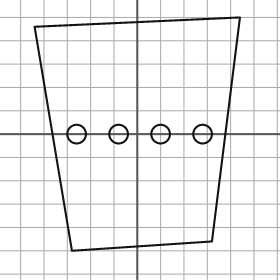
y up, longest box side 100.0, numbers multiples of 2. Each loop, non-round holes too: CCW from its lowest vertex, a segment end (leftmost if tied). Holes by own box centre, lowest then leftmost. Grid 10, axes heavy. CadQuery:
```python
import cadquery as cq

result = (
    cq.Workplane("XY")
    .moveTo(-28.0, -50.0)
    .lineTo(32.0, -46.0)
    .lineTo(44.0, 50.0)
    .lineTo(-44.0, 46.0)
    .close()
    .moveTo(-26.0, 0.0)
    .circle(4.0)
    .moveTo(-8.0, 0.0)
    .circle(4.0)
    .moveTo(10.0, 0.0)
    .circle(4.0)
    .moveTo(28.0, 0.0)
    .circle(4.0)
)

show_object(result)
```